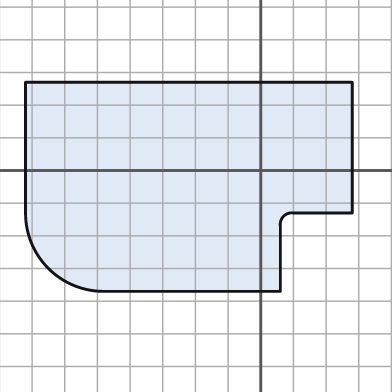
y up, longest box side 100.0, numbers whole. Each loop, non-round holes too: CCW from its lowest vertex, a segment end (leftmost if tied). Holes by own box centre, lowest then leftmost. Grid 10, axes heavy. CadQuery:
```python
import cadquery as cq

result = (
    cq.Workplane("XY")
    .moveTo(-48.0, -37.0)
    .lineTo(6.0, -37.0)
    .lineTo(6.0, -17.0)
    .threePointArc((7.0, -14.0), (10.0, -13.0))
    .lineTo(28.0, -13.0)
    .lineTo(28.0, 27.0)
    .lineTo(-72.0, 27.0)
    .lineTo(-72.0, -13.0)
    .threePointArc((-65.0, -30.0), (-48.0, -37.0))
    .close()
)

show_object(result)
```